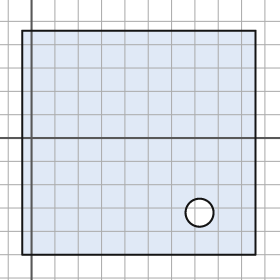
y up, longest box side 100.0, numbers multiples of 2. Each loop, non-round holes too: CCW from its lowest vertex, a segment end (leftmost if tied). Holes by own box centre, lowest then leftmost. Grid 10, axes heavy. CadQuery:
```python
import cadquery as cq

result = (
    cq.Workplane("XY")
    .moveTo(-4.0, -50.0)
    .lineTo(96.0, -50.0)
    .lineTo(96.0, 46.0)
    .lineTo(-4.0, 46.0)
    .close()
    .moveTo(72.0, -32.0)
    .circle(6.0)
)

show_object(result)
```